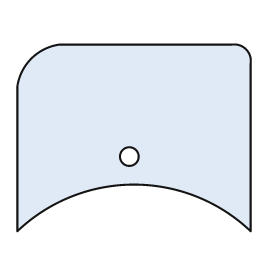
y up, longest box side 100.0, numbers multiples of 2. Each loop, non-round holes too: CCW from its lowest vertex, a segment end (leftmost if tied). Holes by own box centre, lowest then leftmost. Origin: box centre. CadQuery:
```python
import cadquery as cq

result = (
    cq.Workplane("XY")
    .moveTo(-50.0, -40.0)
    .threePointArc((0.0, -20.0), (50.0, -40.0))
    .lineTo(50.0, 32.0)
    .threePointArc((48.0, 38.0), (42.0, 40.0))
    .lineTo(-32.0, 40.0)
    .threePointArc((-44.0, 34.0), (-50.0, 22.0))
    .close()
    .moveTo(-2.0, -8.0)
    .circle(4.0)
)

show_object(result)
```